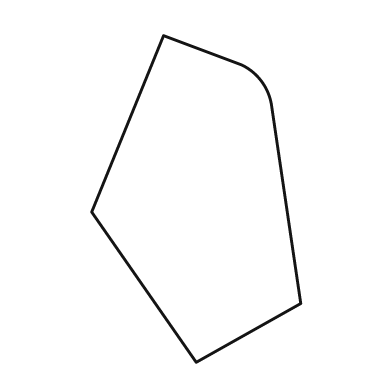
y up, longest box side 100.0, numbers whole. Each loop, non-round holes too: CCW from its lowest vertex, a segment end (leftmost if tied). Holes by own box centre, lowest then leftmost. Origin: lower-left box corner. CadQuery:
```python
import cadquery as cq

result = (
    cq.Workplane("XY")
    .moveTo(32.0, 0.0)
    .lineTo(64.0, 18.0)
    .lineTo(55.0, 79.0)
    .threePointArc((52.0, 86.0), (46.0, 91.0))
    .lineTo(22.0, 100.0)
    .lineTo(0.0, 46.0)
    .close()
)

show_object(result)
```